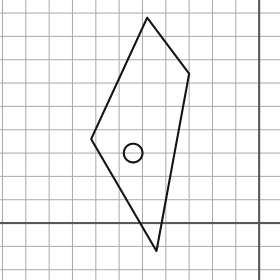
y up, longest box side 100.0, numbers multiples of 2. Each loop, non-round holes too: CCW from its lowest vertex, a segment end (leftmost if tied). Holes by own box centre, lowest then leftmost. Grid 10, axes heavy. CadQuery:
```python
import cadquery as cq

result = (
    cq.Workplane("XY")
    .moveTo(-44.0, -12.0)
    .lineTo(-30.0, 64.0)
    .lineTo(-48.0, 88.0)
    .lineTo(-72.0, 36.0)
    .close()
    .moveTo(-54.0, 30.0)
    .circle(4.0)
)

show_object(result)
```